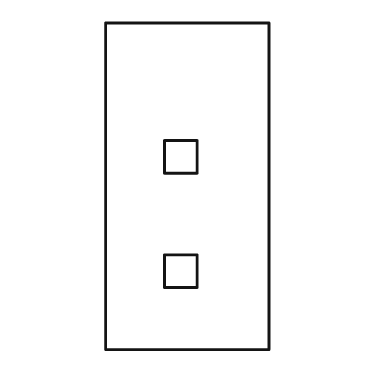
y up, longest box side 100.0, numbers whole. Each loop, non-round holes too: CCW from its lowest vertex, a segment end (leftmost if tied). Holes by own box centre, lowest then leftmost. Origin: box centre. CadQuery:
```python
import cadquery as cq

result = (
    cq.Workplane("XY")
    .moveTo(-25.0, -50.0)
    .lineTo(25.0, -50.0)
    .lineTo(25.0, 50.0)
    .lineTo(-25.0, 50.0)
    .close()
    .moveTo(-7.0, -31.0)
    .lineTo(3.0, -31.0)
    .lineTo(3.0, -21.0)
    .lineTo(-7.0, -21.0)
    .close()
    .moveTo(-7.0, 4.0)
    .lineTo(3.0, 4.0)
    .lineTo(3.0, 14.0)
    .lineTo(-7.0, 14.0)
    .close()
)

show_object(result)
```